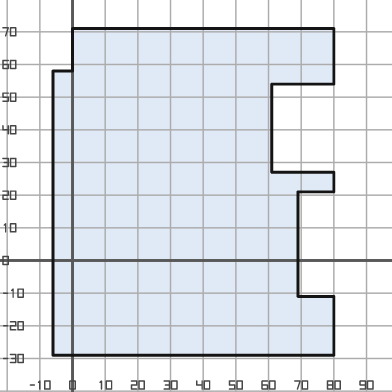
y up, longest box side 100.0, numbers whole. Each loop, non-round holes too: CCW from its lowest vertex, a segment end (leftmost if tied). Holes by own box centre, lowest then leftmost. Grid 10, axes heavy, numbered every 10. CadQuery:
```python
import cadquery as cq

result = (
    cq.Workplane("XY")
    .moveTo(-6.0, -29.0)
    .lineTo(80.0, -29.0)
    .lineTo(80.0, -11.0)
    .lineTo(69.0, -11.0)
    .lineTo(69.0, 21.0)
    .lineTo(80.0, 21.0)
    .lineTo(80.0, 27.0)
    .lineTo(61.0, 27.0)
    .lineTo(61.0, 54.0)
    .lineTo(80.0, 54.0)
    .lineTo(80.0, 71.0)
    .lineTo(0.0, 71.0)
    .lineTo(0.0, 58.0)
    .lineTo(-6.0, 58.0)
    .close()
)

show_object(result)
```